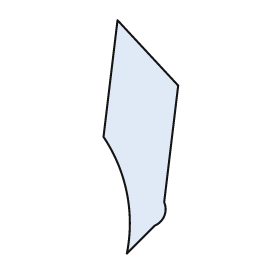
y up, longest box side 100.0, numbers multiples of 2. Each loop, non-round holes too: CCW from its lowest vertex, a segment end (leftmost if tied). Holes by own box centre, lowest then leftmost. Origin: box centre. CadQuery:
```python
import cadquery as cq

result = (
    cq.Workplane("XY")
    .moveTo(-6.0, -50.0)
    .lineTo(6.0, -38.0)
    .threePointArc((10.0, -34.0), (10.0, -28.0))
    .lineTo(16.0, 22.0)
    .lineTo(-10.0, 50.0)
    .lineTo(-16.0, 0.0)
    .threePointArc((-6.0, -24.0), (-6.0, -50.0))
    .close()
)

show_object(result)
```